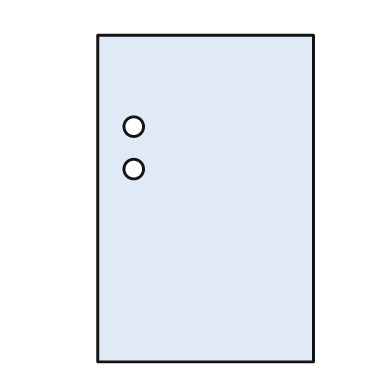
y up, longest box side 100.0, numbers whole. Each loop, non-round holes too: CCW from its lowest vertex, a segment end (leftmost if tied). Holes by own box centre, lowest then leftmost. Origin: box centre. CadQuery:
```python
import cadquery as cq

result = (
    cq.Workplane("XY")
    .moveTo(-33.0, -50.0)
    .lineTo(33.0, -50.0)
    .lineTo(33.0, 50.0)
    .lineTo(-33.0, 50.0)
    .close()
    .moveTo(-22.0, 9.0)
    .circle(3.0)
    .moveTo(-22.0, 22.0)
    .circle(3.0)
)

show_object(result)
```